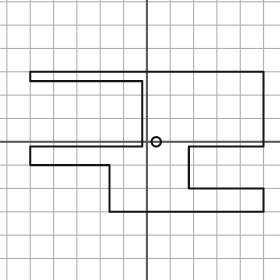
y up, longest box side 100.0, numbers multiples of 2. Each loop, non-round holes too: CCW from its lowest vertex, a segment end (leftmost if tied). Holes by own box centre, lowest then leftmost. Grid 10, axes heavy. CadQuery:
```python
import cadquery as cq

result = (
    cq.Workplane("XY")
    .moveTo(-16.0, -30.0)
    .lineTo(50.0, -30.0)
    .lineTo(50.0, -20.0)
    .lineTo(18.0, -20.0)
    .lineTo(18.0, -2.0)
    .lineTo(50.0, -2.0)
    .lineTo(50.0, 30.0)
    .lineTo(-50.0, 30.0)
    .lineTo(-50.0, 26.0)
    .lineTo(-2.0, 26.0)
    .lineTo(-2.0, -2.0)
    .lineTo(-50.0, -2.0)
    .lineTo(-50.0, -10.0)
    .lineTo(-16.0, -10.0)
    .close()
    .moveTo(4.0, 0.0)
    .circle(2.0)
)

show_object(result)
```